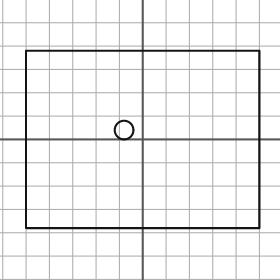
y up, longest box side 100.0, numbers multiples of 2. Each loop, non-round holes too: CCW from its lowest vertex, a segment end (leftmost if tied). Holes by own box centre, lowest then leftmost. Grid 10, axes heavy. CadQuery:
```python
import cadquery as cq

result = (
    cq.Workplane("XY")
    .moveTo(-50.0, -38.0)
    .lineTo(50.0, -38.0)
    .lineTo(50.0, 38.0)
    .lineTo(-50.0, 38.0)
    .close()
    .moveTo(-8.0, 4.0)
    .circle(4.0)
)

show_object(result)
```